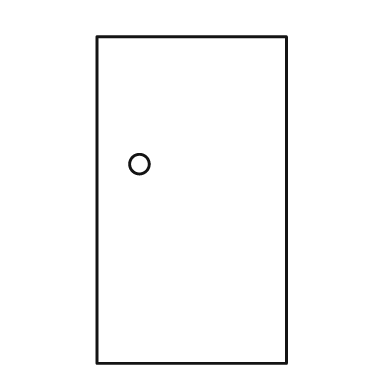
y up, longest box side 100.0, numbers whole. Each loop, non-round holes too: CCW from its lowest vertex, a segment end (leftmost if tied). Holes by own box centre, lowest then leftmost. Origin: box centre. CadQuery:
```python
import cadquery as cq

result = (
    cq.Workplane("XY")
    .moveTo(-29.0, -50.0)
    .lineTo(29.0, -50.0)
    .lineTo(29.0, 50.0)
    .lineTo(-29.0, 50.0)
    .close()
    .moveTo(-16.0, 11.0)
    .circle(3.0)
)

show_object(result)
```